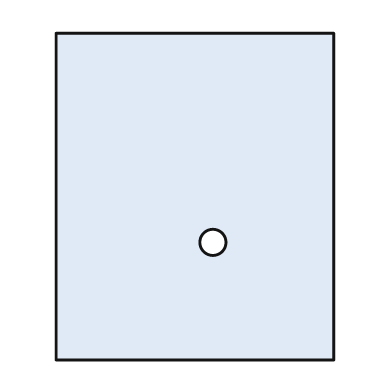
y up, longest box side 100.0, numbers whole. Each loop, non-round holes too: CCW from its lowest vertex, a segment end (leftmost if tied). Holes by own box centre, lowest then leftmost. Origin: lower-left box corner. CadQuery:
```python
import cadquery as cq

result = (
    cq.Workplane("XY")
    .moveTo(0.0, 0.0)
    .lineTo(85.0, 0.0)
    .lineTo(85.0, 100.0)
    .lineTo(0.0, 100.0)
    .close()
    .moveTo(48.0, 36.0)
    .circle(4.0)
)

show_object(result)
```